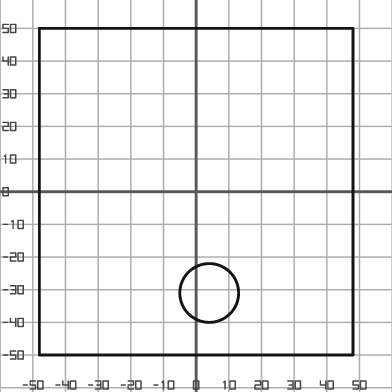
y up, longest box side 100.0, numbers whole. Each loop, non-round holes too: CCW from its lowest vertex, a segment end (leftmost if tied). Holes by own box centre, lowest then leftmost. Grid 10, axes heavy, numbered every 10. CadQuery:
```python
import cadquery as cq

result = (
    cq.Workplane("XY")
    .moveTo(-48.0, -50.0)
    .lineTo(48.0, -50.0)
    .lineTo(48.0, 50.0)
    .lineTo(-48.0, 50.0)
    .close()
    .moveTo(4.0, -31.0)
    .circle(9.0)
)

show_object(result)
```